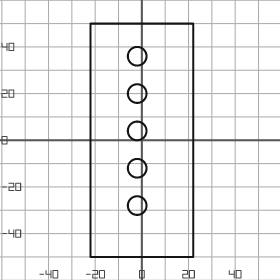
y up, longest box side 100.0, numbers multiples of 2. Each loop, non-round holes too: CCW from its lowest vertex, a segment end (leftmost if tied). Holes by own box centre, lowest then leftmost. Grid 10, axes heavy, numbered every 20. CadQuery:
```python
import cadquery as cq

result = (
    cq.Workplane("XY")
    .moveTo(-22.0, -50.0)
    .lineTo(22.0, -50.0)
    .lineTo(22.0, 50.0)
    .lineTo(-22.0, 50.0)
    .close()
    .moveTo(-2.0, -28.0)
    .circle(4.0)
    .moveTo(-2.0, -12.0)
    .circle(4.0)
    .moveTo(-2.0, 4.0)
    .circle(4.0)
    .moveTo(-2.0, 20.0)
    .circle(4.0)
    .moveTo(-2.0, 36.0)
    .circle(4.0)
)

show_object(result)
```